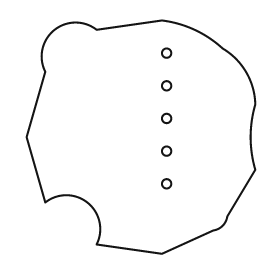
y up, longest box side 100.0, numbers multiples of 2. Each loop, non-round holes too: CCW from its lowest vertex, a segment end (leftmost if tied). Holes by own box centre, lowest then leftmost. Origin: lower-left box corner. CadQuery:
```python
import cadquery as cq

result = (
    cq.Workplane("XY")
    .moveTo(58.0, 0.0)
    .lineTo(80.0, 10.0)
    .threePointArc((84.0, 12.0), (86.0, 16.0))
    .lineTo(98.0, 36.0)
    .threePointArc((96.0, 50.0), (98.0, 64.0))
    .threePointArc((94.0, 78.0), (84.0, 88.0))
    .threePointArc((72.0, 96.0), (58.0, 100.0))
    .lineTo(30.0, 96.0)
    .threePointArc((12.0, 96.0), (8.0, 78.0))
    .lineTo(0.0, 50.0)
    .lineTo(8.0, 22.0)
    .threePointArc((26.0, 22.0), (30.0, 4.0))
    .close()
    .moveTo(60.0, 30.0)
    .circle(2.0)
    .moveTo(60.0, 44.0)
    .circle(2.0)
    .moveTo(60.0, 58.0)
    .circle(2.0)
    .moveTo(60.0, 72.0)
    .circle(2.0)
    .moveTo(60.0, 86.0)
    .circle(2.0)
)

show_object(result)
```